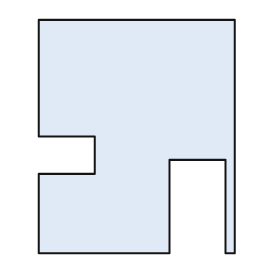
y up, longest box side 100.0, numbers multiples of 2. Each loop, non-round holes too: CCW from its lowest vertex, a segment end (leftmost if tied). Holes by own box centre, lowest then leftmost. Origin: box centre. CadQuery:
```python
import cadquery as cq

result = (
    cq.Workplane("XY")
    .moveTo(-42.0, -50.0)
    .lineTo(14.0, -50.0)
    .lineTo(14.0, -10.0)
    .lineTo(38.0, -10.0)
    .lineTo(38.0, -50.0)
    .lineTo(42.0, -50.0)
    .lineTo(42.0, 50.0)
    .lineTo(-42.0, 50.0)
    .lineTo(-42.0, 0.0)
    .lineTo(-18.0, 0.0)
    .lineTo(-18.0, -16.0)
    .lineTo(-42.0, -16.0)
    .close()
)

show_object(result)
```